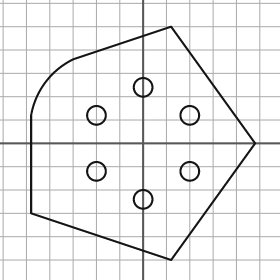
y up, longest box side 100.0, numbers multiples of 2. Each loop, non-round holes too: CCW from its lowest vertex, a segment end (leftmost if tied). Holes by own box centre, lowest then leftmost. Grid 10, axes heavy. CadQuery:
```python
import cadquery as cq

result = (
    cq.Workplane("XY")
    .moveTo(12.0, -50.0)
    .lineTo(48.0, 0.0)
    .lineTo(12.0, 50.0)
    .lineTo(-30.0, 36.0)
    .threePointArc((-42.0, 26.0), (-48.0, 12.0))
    .lineTo(-48.0, -30.0)
    .close()
    .moveTo(0.0, -24.0)
    .circle(4.0)
    .moveTo(-20.0, -12.0)
    .circle(4.0)
    .moveTo(20.0, -12.0)
    .circle(4.0)
    .moveTo(-20.0, 12.0)
    .circle(4.0)
    .moveTo(20.0, 12.0)
    .circle(4.0)
    .moveTo(0.0, 24.0)
    .circle(4.0)
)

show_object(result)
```